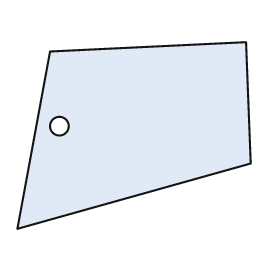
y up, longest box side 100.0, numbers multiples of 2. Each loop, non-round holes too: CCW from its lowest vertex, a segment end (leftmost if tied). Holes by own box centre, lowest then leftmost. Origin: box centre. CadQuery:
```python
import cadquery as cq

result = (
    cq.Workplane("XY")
    .moveTo(-50.0, -40.0)
    .lineTo(50.0, -12.0)
    .lineTo(48.0, 40.0)
    .lineTo(-36.0, 36.0)
    .close()
    .moveTo(-32.0, 4.0)
    .circle(4.0)
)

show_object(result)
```